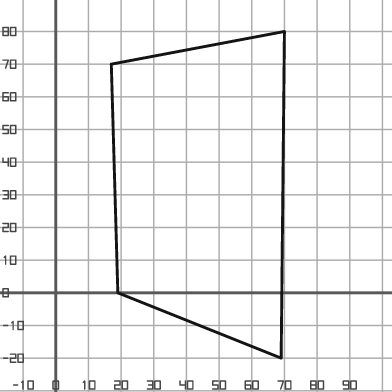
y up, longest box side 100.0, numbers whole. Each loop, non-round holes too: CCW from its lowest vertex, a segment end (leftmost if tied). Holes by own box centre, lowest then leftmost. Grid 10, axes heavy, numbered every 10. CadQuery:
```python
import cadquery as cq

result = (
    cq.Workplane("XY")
    .moveTo(69.0, -20.0)
    .lineTo(70.0, 80.0)
    .lineTo(17.0, 70.0)
    .lineTo(19.0, 0.0)
    .close()
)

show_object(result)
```